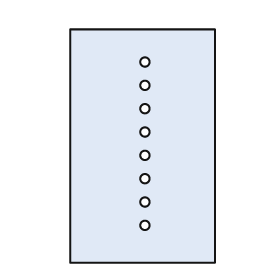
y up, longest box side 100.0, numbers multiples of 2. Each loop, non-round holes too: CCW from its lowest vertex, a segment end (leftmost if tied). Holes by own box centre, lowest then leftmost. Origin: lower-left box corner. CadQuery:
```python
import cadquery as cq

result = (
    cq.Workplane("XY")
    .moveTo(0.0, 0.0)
    .lineTo(62.0, 0.0)
    .lineTo(62.0, 100.0)
    .lineTo(0.0, 100.0)
    .close()
    .moveTo(32.0, 16.0)
    .circle(2.0)
    .moveTo(32.0, 26.0)
    .circle(2.0)
    .moveTo(32.0, 36.0)
    .circle(2.0)
    .moveTo(32.0, 46.0)
    .circle(2.0)
    .moveTo(32.0, 56.0)
    .circle(2.0)
    .moveTo(32.0, 66.0)
    .circle(2.0)
    .moveTo(32.0, 76.0)
    .circle(2.0)
    .moveTo(32.0, 86.0)
    .circle(2.0)
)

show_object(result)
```